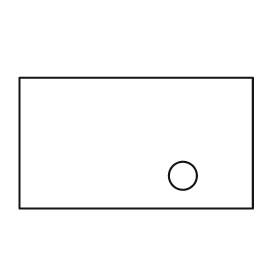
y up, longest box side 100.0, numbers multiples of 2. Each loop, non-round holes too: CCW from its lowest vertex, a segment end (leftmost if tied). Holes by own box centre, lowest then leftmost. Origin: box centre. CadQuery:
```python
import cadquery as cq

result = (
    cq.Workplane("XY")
    .moveTo(-50.0, -28.0)
    .lineTo(50.0, -28.0)
    .lineTo(50.0, 28.0)
    .lineTo(-50.0, 28.0)
    .close()
    .moveTo(20.0, -14.0)
    .circle(6.0)
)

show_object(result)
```